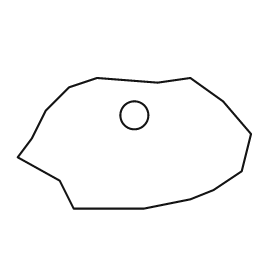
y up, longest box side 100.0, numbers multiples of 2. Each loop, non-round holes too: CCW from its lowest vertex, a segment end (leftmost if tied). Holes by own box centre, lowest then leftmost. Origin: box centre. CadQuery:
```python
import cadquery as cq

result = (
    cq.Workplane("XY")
    .moveTo(-26.0, -28.0)
    .lineTo(4.0, -28.0)
    .lineTo(24.0, -24.0)
    .lineTo(34.0, -20.0)
    .lineTo(46.0, -12.0)
    .lineTo(50.0, 4.0)
    .lineTo(38.0, 18.0)
    .lineTo(24.0, 28.0)
    .lineTo(10.0, 26.0)
    .lineTo(-16.0, 28.0)
    .lineTo(-28.0, 24.0)
    .lineTo(-38.0, 14.0)
    .lineTo(-44.0, 2.0)
    .lineTo(-50.0, -6.0)
    .lineTo(-32.0, -16.0)
    .close()
    .moveTo(0.0, 12.0)
    .circle(6.0)
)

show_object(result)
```